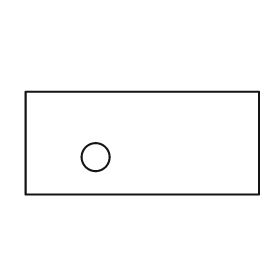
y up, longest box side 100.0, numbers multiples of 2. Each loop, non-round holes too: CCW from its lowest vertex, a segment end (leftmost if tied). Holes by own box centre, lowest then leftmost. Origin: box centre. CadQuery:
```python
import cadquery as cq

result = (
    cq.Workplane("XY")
    .moveTo(-50.0, -22.0)
    .lineTo(50.0, -22.0)
    .lineTo(50.0, 22.0)
    .lineTo(-50.0, 22.0)
    .close()
    .moveTo(-20.0, -6.0)
    .circle(6.0)
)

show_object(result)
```